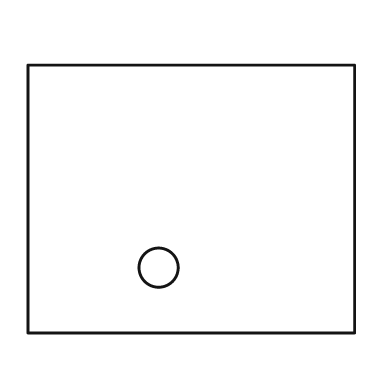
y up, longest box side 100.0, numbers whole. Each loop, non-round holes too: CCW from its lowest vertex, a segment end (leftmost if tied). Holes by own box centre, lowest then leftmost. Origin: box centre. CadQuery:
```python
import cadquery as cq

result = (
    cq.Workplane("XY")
    .moveTo(-50.0, -41.0)
    .lineTo(50.0, -41.0)
    .lineTo(50.0, 41.0)
    .lineTo(-50.0, 41.0)
    .close()
    .moveTo(-10.0, -21.0)
    .circle(6.0)
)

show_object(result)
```